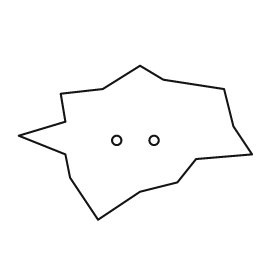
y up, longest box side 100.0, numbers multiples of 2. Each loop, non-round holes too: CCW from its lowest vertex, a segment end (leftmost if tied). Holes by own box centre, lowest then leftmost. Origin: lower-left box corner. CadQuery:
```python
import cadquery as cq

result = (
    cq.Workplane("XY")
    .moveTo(34.0, 0.0)
    .lineTo(52.0, 12.0)
    .lineTo(68.0, 16.0)
    .lineTo(76.0, 26.0)
    .lineTo(100.0, 28.0)
    .lineTo(92.0, 40.0)
    .lineTo(88.0, 56.0)
    .lineTo(62.0, 60.0)
    .lineTo(52.0, 66.0)
    .lineTo(36.0, 56.0)
    .lineTo(18.0, 54.0)
    .lineTo(20.0, 42.0)
    .lineTo(0.0, 36.0)
    .lineTo(20.0, 28.0)
    .lineTo(22.0, 18.0)
    .close()
    .moveTo(42.0, 34.0)
    .circle(2.0)
    .moveTo(58.0, 34.0)
    .circle(2.0)
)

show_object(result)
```